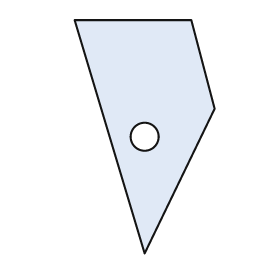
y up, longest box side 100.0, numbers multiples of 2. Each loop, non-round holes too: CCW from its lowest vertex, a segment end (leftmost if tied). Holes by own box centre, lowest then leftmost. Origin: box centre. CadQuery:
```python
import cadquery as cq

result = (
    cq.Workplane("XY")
    .moveTo(0.0, -50.0)
    .lineTo(30.0, 12.0)
    .lineTo(20.0, 50.0)
    .lineTo(-30.0, 50.0)
    .close()
    .moveTo(0.0, 0.0)
    .circle(6.0)
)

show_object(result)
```